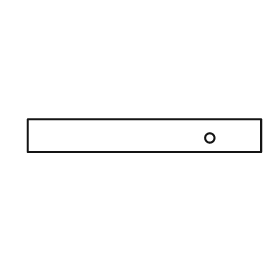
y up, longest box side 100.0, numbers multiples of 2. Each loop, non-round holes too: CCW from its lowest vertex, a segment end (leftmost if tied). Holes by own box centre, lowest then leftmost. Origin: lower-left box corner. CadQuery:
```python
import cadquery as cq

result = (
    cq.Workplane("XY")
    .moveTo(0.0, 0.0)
    .lineTo(100.0, 0.0)
    .lineTo(100.0, 14.0)
    .lineTo(0.0, 14.0)
    .close()
    .moveTo(78.0, 6.0)
    .circle(2.0)
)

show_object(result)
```